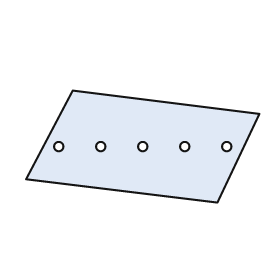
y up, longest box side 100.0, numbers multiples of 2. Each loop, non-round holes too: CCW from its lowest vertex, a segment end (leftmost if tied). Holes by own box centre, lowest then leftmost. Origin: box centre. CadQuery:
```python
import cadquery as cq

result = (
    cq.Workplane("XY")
    .moveTo(32.0, -24.0)
    .lineTo(50.0, 14.0)
    .lineTo(-30.0, 24.0)
    .lineTo(-50.0, -14.0)
    .close()
    .moveTo(-36.0, 0.0)
    .circle(2.0)
    .moveTo(-18.0, 0.0)
    .circle(2.0)
    .moveTo(0.0, 0.0)
    .circle(2.0)
    .moveTo(18.0, 0.0)
    .circle(2.0)
    .moveTo(36.0, 0.0)
    .circle(2.0)
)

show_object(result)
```